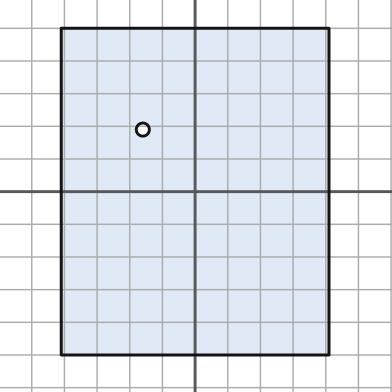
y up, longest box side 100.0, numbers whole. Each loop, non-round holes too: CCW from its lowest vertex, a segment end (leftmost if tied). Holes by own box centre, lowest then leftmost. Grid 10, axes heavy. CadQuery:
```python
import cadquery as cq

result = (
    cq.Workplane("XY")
    .moveTo(-41.0, -50.0)
    .lineTo(41.0, -50.0)
    .lineTo(41.0, 50.0)
    .lineTo(-41.0, 50.0)
    .close()
    .moveTo(-16.0, 19.0)
    .circle(2.0)
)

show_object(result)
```